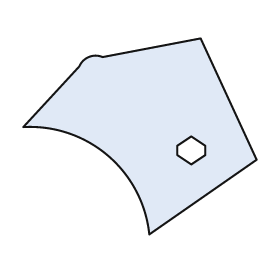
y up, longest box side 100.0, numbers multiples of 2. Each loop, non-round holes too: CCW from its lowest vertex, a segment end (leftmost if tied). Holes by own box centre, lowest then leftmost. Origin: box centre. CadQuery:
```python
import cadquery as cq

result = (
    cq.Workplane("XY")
    .moveTo(4.0, -42.0)
    .lineTo(50.0, -10.0)
    .lineTo(26.0, 42.0)
    .lineTo(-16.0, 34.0)
    .threePointArc((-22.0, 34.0), (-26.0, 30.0))
    .lineTo(-50.0, 4.0)
    .threePointArc((-14.0, -8.0), (4.0, -42.0))
    .close()
    .moveTo(22.0, -12.0)
    .lineTo(28.0, -8.0)
    .lineTo(28.0, -4.0)
    .lineTo(22.0, 0.0)
    .lineTo(16.0, -4.0)
    .lineTo(16.0, -8.0)
    .close()
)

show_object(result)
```